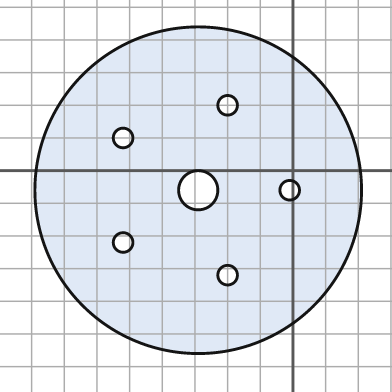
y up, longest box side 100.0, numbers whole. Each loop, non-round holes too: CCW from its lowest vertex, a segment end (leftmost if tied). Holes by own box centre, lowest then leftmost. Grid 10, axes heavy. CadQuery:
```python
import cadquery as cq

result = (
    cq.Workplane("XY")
    .moveTo(-29.0, -6.0)
    .circle(50.0)
    .moveTo(-20.0, -32.0)
    .circle(3.0)
    .moveTo(-52.0, -22.0)
    .circle(3.0)
    .moveTo(-29.0, -6.0)
    .circle(6.0)
    .moveTo(-1.0, -6.0)
    .circle(3.0)
    .moveTo(-52.0, 10.0)
    .circle(3.0)
    .moveTo(-20.0, 20.0)
    .circle(3.0)
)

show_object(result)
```